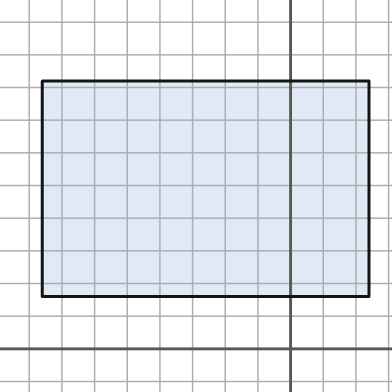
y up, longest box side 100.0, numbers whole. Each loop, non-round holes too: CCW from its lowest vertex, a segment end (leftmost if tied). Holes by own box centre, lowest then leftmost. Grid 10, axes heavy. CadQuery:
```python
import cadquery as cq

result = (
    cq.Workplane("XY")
    .moveTo(-76.0, 16.0)
    .lineTo(24.0, 16.0)
    .lineTo(24.0, 82.0)
    .lineTo(-76.0, 82.0)
    .close()
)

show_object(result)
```